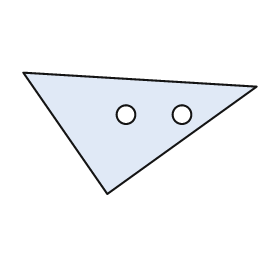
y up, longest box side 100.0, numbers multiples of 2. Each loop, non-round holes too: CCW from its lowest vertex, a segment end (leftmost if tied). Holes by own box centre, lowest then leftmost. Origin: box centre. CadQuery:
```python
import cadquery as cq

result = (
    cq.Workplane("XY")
    .moveTo(-14.0, -26.0)
    .lineTo(50.0, 20.0)
    .lineTo(-50.0, 26.0)
    .close()
    .moveTo(-6.0, 8.0)
    .circle(4.0)
    .moveTo(18.0, 8.0)
    .circle(4.0)
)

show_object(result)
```